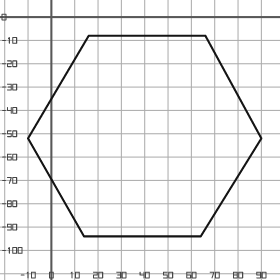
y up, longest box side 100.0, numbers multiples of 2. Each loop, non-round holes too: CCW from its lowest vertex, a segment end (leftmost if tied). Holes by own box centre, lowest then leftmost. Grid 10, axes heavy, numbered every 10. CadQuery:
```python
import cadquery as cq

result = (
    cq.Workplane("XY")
    .moveTo(14.0, -94.0)
    .lineTo(64.0, -94.0)
    .lineTo(90.0, -52.0)
    .lineTo(66.0, -8.0)
    .lineTo(16.0, -8.0)
    .lineTo(-10.0, -52.0)
    .close()
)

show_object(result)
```